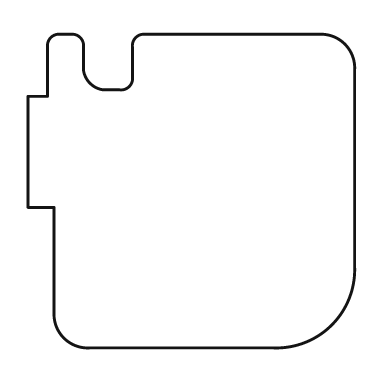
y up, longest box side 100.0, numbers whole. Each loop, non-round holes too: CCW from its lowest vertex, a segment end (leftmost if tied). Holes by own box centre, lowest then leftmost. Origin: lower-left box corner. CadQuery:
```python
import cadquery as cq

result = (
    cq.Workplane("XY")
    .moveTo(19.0, 0.0)
    .lineTo(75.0, 0.0)
    .threePointArc((93.0, 7.0), (100.0, 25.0))
    .lineTo(100.0, 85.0)
    .threePointArc((97.0, 93.0), (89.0, 96.0))
    .lineTo(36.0, 96.0)
    .threePointArc((33.0, 95.0), (32.0, 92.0))
    .lineTo(32.0, 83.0)
    .threePointArc((31.0, 80.0), (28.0, 79.0))
    .lineTo(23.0, 79.0)
    .threePointArc((19.0, 81.0), (17.0, 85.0))
    .lineTo(17.0, 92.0)
    .threePointArc((16.0, 95.0), (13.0, 96.0))
    .lineTo(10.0, 96.0)
    .threePointArc((7.0, 95.0), (6.0, 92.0))
    .lineTo(6.0, 77.0)
    .lineTo(0.0, 77.0)
    .lineTo(0.0, 43.0)
    .lineTo(8.0, 43.0)
    .lineTo(8.0, 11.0)
    .threePointArc((11.0, 3.0), (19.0, 0.0))
    .close()
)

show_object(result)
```